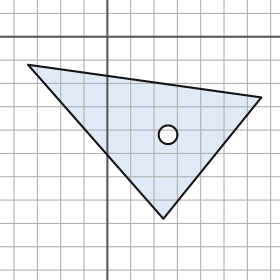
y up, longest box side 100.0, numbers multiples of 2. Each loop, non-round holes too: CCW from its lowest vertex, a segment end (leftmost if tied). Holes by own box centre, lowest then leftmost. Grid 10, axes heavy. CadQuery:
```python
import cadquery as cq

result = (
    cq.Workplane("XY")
    .moveTo(24.0, -78.0)
    .lineTo(66.0, -26.0)
    .lineTo(-34.0, -12.0)
    .close()
    .moveTo(26.0, -42.0)
    .circle(4.0)
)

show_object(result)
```